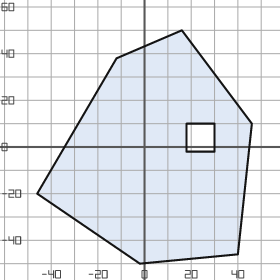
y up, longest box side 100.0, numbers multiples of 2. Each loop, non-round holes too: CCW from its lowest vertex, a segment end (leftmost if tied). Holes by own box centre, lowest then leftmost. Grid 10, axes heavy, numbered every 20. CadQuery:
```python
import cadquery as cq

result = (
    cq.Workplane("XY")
    .moveTo(-2.0, -50.0)
    .lineTo(40.0, -46.0)
    .lineTo(46.0, 10.0)
    .lineTo(16.0, 50.0)
    .lineTo(-12.0, 38.0)
    .lineTo(-46.0, -20.0)
    .close()
    .moveTo(18.0, -2.0)
    .lineTo(30.0, -2.0)
    .lineTo(30.0, 10.0)
    .lineTo(18.0, 10.0)
    .close()
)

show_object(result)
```